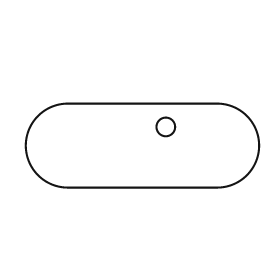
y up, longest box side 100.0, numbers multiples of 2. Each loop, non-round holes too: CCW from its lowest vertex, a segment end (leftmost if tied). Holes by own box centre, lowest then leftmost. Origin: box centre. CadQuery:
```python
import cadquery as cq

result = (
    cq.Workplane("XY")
    .moveTo(-32.0, -18.0)
    .lineTo(32.0, -18.0)
    .threePointArc((50.0, 0.0), (32.0, 18.0))
    .lineTo(-32.0, 18.0)
    .threePointArc((-50.0, 0.0), (-32.0, -18.0))
    .close()
    .moveTo(10.0, 8.0)
    .circle(4.0)
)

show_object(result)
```